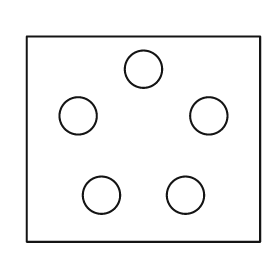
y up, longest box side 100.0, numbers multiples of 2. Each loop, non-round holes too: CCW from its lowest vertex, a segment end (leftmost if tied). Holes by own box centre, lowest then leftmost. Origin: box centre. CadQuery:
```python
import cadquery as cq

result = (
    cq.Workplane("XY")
    .moveTo(-50.0, -44.0)
    .lineTo(50.0, -44.0)
    .lineTo(50.0, 44.0)
    .lineTo(-50.0, 44.0)
    .close()
    .moveTo(-18.0, -24.0)
    .circle(8.0)
    .moveTo(18.0, -24.0)
    .circle(8.0)
    .moveTo(-28.0, 10.0)
    .circle(8.0)
    .moveTo(28.0, 10.0)
    .circle(8.0)
    .moveTo(0.0, 30.0)
    .circle(8.0)
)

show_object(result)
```